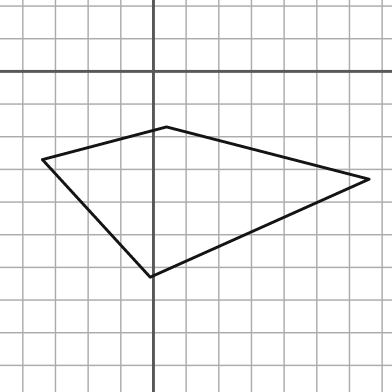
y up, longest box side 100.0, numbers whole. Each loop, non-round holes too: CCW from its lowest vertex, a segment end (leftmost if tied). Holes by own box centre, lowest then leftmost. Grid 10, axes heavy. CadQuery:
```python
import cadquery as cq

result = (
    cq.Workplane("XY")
    .moveTo(-1.0, -63.0)
    .lineTo(66.0, -33.0)
    .lineTo(4.0, -17.0)
    .lineTo(-34.0, -27.0)
    .close()
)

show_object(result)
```